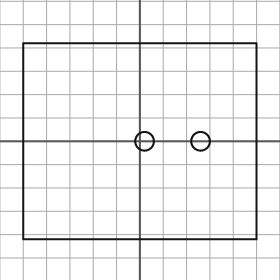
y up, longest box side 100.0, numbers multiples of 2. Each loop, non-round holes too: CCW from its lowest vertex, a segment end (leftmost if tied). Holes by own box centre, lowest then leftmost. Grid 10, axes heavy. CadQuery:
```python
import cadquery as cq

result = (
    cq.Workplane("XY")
    .moveTo(-50.0, -42.0)
    .lineTo(50.0, -42.0)
    .lineTo(50.0, 42.0)
    .lineTo(-50.0, 42.0)
    .close()
    .moveTo(2.0, 0.0)
    .circle(4.0)
    .moveTo(26.0, 0.0)
    .circle(4.0)
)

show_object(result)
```